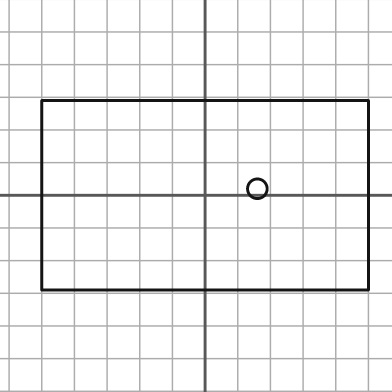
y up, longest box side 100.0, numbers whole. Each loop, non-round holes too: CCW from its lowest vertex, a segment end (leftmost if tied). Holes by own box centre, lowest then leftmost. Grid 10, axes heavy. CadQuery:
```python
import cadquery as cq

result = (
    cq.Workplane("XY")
    .moveTo(-50.0, -29.0)
    .lineTo(50.0, -29.0)
    .lineTo(50.0, 29.0)
    .lineTo(-50.0, 29.0)
    .close()
    .moveTo(16.0, 2.0)
    .circle(3.0)
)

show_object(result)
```